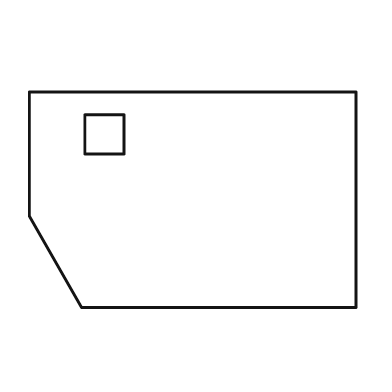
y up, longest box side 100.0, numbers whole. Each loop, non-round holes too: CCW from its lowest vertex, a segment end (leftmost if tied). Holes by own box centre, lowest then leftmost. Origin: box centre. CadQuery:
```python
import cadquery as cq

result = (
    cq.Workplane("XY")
    .moveTo(-34.0, -33.0)
    .lineTo(50.0, -33.0)
    .lineTo(50.0, 33.0)
    .lineTo(-50.0, 33.0)
    .lineTo(-50.0, -5.0)
    .close()
    .moveTo(-33.0, 14.0)
    .lineTo(-21.0, 14.0)
    .lineTo(-21.0, 26.0)
    .lineTo(-33.0, 26.0)
    .close()
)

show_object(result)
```